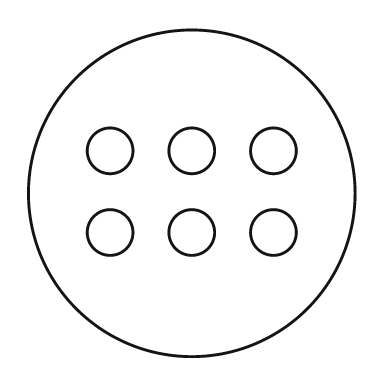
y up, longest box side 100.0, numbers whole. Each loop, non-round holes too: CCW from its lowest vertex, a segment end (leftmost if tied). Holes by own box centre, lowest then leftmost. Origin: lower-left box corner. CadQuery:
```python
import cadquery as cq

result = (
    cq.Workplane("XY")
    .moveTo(50.0, 50.0)
    .circle(50.0)
    .moveTo(25.0, 38.0)
    .circle(7.0)
    .moveTo(50.0, 38.0)
    .circle(7.0)
    .moveTo(75.0, 38.0)
    .circle(7.0)
    .moveTo(25.0, 63.0)
    .circle(7.0)
    .moveTo(50.0, 63.0)
    .circle(7.0)
    .moveTo(75.0, 63.0)
    .circle(7.0)
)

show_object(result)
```